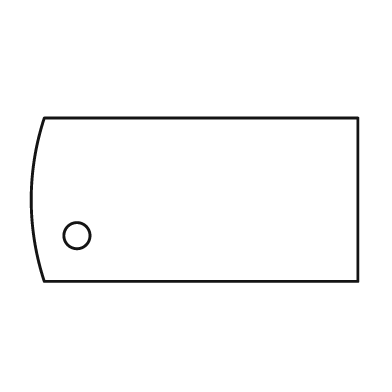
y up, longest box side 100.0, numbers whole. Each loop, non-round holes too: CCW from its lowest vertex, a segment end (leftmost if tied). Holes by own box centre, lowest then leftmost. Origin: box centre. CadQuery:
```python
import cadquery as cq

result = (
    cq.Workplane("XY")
    .moveTo(-46.0, -25.0)
    .lineTo(50.0, -25.0)
    .lineTo(50.0, 25.0)
    .lineTo(-46.0, 25.0)
    .threePointArc((-50.0, 0.0), (-46.0, -25.0))
    .close()
    .moveTo(-36.0, -11.0)
    .circle(4.0)
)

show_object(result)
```